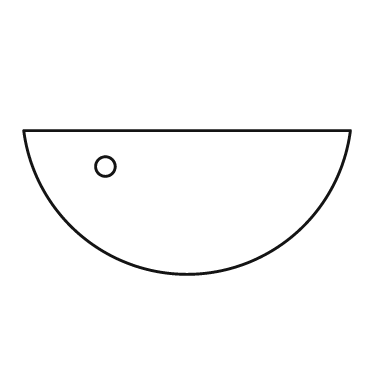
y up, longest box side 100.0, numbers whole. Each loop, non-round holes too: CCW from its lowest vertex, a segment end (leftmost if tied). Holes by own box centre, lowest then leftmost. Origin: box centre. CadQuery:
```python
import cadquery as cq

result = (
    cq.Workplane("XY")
    .moveTo(-50.0, 22.0)
    .threePointArc((0.0, -22.0), (50.0, 22.0))
    .close()
    .moveTo(-25.0, 11.0)
    .circle(3.0)
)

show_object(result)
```